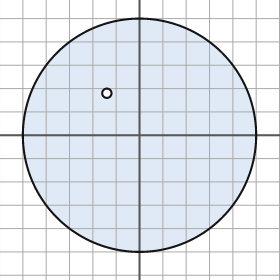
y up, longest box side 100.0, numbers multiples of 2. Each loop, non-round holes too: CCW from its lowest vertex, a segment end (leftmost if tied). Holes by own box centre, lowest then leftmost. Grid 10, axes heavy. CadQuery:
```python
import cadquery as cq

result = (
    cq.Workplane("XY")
    .moveTo(0.0, 0.0)
    .circle(50.0)
    .moveTo(-14.0, 18.0)
    .circle(2.0)
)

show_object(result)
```